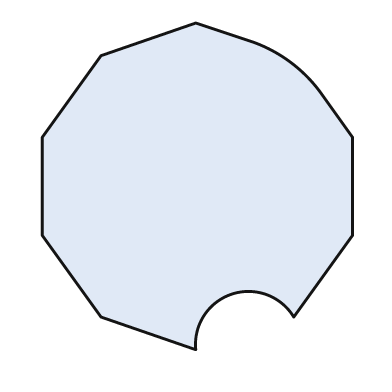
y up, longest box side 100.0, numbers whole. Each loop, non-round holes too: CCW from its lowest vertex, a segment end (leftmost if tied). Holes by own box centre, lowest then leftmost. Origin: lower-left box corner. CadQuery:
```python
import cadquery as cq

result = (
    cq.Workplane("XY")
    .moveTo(47.0, 0.0)
    .threePointArc((58.0, 17.0), (77.0, 10.0))
    .lineTo(95.0, 35.0)
    .lineTo(95.0, 65.0)
    .lineTo(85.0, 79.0)
    .threePointArc((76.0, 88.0), (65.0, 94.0))
    .lineTo(47.0, 100.0)
    .lineTo(18.0, 90.0)
    .lineTo(0.0, 65.0)
    .lineTo(0.0, 35.0)
    .lineTo(18.0, 10.0)
    .close()
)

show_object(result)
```